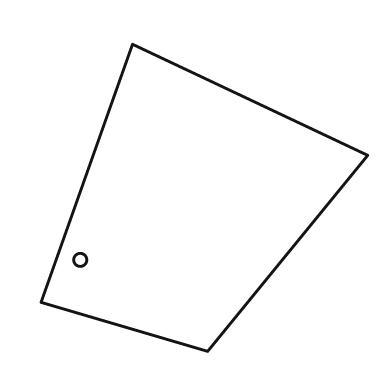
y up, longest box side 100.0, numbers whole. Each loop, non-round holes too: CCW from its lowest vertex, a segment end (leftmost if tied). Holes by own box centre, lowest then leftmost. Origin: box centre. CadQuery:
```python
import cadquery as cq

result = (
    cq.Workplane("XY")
    .moveTo(1.0, -47.0)
    .lineTo(50.0, 13.0)
    .lineTo(-22.0, 47.0)
    .lineTo(-50.0, -32.0)
    .close()
    .moveTo(-38.0, -19.0)
    .circle(2.0)
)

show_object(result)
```